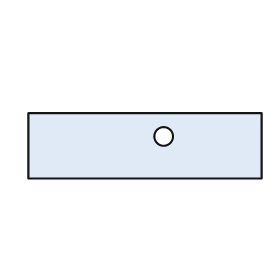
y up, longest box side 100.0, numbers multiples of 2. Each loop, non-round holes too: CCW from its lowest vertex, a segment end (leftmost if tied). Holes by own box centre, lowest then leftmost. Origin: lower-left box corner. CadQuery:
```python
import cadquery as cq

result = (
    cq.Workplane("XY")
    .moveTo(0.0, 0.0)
    .lineTo(100.0, 0.0)
    .lineTo(100.0, 28.0)
    .lineTo(0.0, 28.0)
    .close()
    .moveTo(58.0, 18.0)
    .circle(4.0)
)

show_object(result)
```